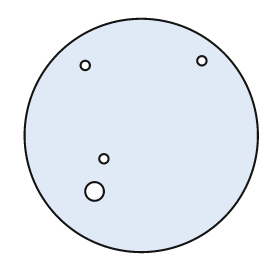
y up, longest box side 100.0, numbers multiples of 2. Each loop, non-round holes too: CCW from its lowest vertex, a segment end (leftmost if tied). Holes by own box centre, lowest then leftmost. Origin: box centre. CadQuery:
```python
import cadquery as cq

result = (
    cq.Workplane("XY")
    .moveTo(0.0, 0.0)
    .circle(50.0)
    .moveTo(-20.0, -24.0)
    .circle(4.0)
    .moveTo(-16.0, -10.0)
    .circle(2.0)
    .moveTo(-24.0, 30.0)
    .circle(2.0)
    .moveTo(26.0, 32.0)
    .circle(2.0)
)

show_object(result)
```